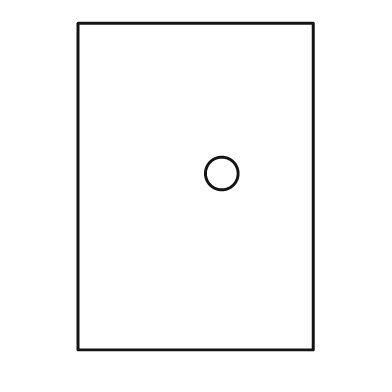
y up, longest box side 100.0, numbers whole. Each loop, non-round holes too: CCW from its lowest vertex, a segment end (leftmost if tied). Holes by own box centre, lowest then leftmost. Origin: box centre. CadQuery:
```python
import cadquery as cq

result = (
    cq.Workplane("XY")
    .moveTo(-36.0, -50.0)
    .lineTo(36.0, -50.0)
    .lineTo(36.0, 50.0)
    .lineTo(-36.0, 50.0)
    .close()
    .moveTo(8.0, 4.0)
    .circle(5.0)
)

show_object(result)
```